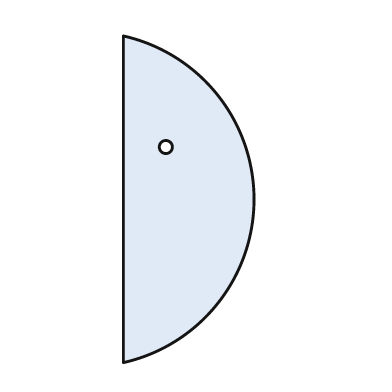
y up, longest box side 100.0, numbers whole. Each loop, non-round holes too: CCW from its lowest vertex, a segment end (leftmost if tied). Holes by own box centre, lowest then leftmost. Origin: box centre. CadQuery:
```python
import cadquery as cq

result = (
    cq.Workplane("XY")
    .moveTo(-20.0, -50.0)
    .threePointArc((20.0, 0.0), (-20.0, 50.0))
    .close()
    .moveTo(-7.0, 16.0)
    .circle(2.0)
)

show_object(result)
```